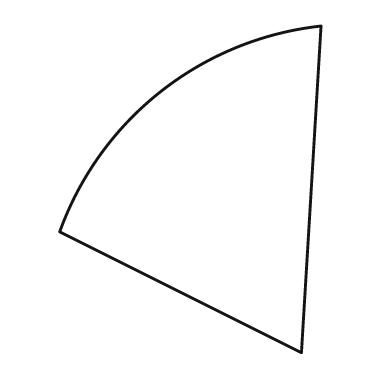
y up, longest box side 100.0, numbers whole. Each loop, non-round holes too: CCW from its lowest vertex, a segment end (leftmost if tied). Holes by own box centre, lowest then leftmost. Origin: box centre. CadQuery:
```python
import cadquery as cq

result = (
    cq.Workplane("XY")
    .moveTo(34.0, -50.0)
    .lineTo(40.0, 50.0)
    .threePointArc((-9.0, 30.0), (-40.0, -13.0))
    .close()
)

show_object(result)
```